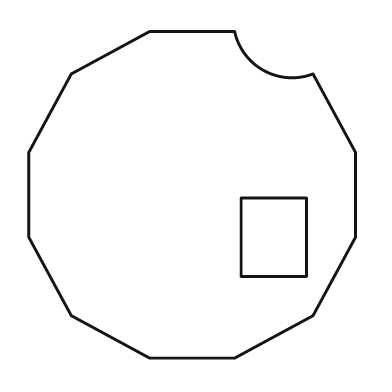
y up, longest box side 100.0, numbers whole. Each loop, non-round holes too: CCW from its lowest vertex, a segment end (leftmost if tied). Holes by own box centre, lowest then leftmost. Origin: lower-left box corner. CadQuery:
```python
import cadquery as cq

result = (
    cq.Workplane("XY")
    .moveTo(37.0, 0.0)
    .lineTo(63.0, 0.0)
    .lineTo(87.0, 13.0)
    .lineTo(100.0, 37.0)
    .lineTo(100.0, 63.0)
    .lineTo(87.0, 87.0)
    .threePointArc((72.0, 88.0), (63.0, 100.0))
    .lineTo(37.0, 100.0)
    .lineTo(13.0, 87.0)
    .lineTo(0.0, 63.0)
    .lineTo(0.0, 37.0)
    .lineTo(13.0, 13.0)
    .close()
    .moveTo(65.0, 25.0)
    .lineTo(85.0, 25.0)
    .lineTo(85.0, 49.0)
    .lineTo(65.0, 49.0)
    .close()
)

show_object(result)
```